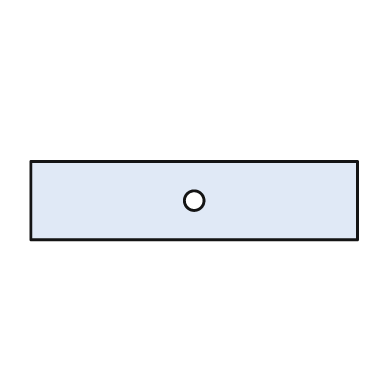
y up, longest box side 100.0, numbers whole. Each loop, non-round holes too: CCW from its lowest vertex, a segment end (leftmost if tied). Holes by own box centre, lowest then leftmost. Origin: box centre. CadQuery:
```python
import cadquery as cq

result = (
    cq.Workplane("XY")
    .moveTo(-50.0, -12.0)
    .lineTo(50.0, -12.0)
    .lineTo(50.0, 12.0)
    .lineTo(-50.0, 12.0)
    .close()
    .moveTo(0.0, 0.0)
    .circle(3.0)
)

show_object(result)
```